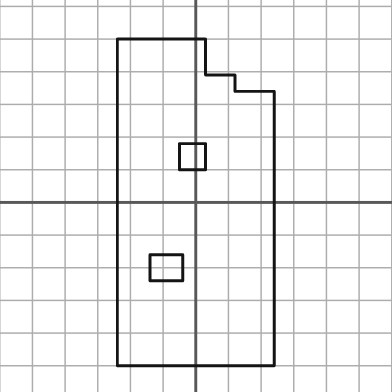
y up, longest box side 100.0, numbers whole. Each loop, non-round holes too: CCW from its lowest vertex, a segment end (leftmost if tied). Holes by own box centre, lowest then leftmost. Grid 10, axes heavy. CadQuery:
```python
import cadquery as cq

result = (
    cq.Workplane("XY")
    .moveTo(-24.0, -50.0)
    .lineTo(24.0, -50.0)
    .lineTo(24.0, 34.0)
    .lineTo(12.0, 34.0)
    .lineTo(12.0, 39.0)
    .lineTo(3.0, 39.0)
    .lineTo(3.0, 50.0)
    .lineTo(-24.0, 50.0)
    .close()
    .moveTo(-14.0, -24.0)
    .lineTo(-4.0, -24.0)
    .lineTo(-4.0, -16.0)
    .lineTo(-14.0, -16.0)
    .close()
    .moveTo(-5.0, 10.0)
    .lineTo(3.0, 10.0)
    .lineTo(3.0, 18.0)
    .lineTo(-5.0, 18.0)
    .close()
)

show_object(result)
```